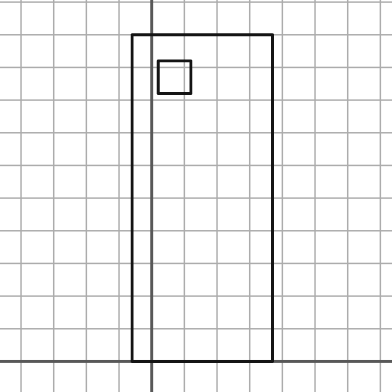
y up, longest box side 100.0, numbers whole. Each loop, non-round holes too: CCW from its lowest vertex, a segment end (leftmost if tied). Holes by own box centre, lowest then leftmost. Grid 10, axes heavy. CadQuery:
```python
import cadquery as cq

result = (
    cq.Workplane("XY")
    .moveTo(-6.0, 0.0)
    .lineTo(37.0, 0.0)
    .lineTo(37.0, 100.0)
    .lineTo(-6.0, 100.0)
    .close()
    .moveTo(2.0, 82.0)
    .lineTo(12.0, 82.0)
    .lineTo(12.0, 92.0)
    .lineTo(2.0, 92.0)
    .close()
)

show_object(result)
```